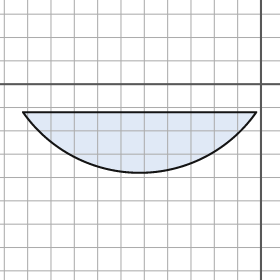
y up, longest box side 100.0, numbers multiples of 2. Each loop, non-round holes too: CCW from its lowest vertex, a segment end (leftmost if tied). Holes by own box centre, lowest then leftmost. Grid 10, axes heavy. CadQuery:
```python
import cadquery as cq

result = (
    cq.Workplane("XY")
    .moveTo(-102.0, -12.0)
    .threePointArc((-52.0, -38.0), (-2.0, -12.0))
    .close()
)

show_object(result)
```